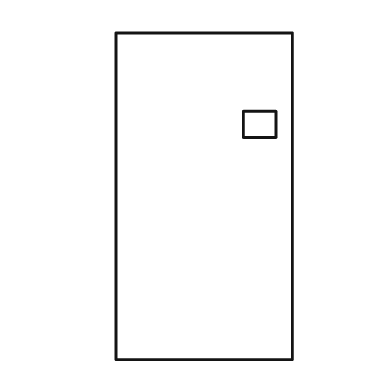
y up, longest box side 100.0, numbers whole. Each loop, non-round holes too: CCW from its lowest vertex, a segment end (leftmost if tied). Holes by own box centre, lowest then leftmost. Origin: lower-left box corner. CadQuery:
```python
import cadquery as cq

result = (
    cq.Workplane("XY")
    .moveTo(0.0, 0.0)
    .lineTo(54.0, 0.0)
    .lineTo(54.0, 100.0)
    .lineTo(0.0, 100.0)
    .close()
    .moveTo(39.0, 68.0)
    .lineTo(49.0, 68.0)
    .lineTo(49.0, 76.0)
    .lineTo(39.0, 76.0)
    .close()
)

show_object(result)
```